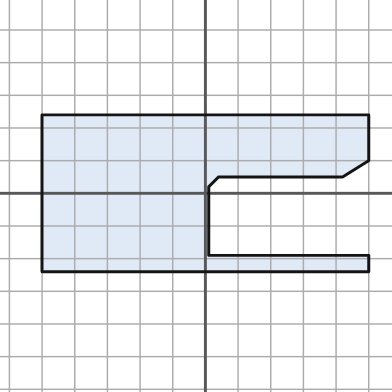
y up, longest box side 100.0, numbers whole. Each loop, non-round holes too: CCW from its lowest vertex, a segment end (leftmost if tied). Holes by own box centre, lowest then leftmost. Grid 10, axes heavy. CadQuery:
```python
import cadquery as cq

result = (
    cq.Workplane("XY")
    .moveTo(-50.0, -24.0)
    .lineTo(50.0, -24.0)
    .lineTo(50.0, -19.0)
    .lineTo(1.0, -19.0)
    .lineTo(1.0, 2.0)
    .lineTo(4.0, 5.0)
    .lineTo(42.0, 5.0)
    .lineTo(50.0, 10.0)
    .lineTo(50.0, 24.0)
    .lineTo(-50.0, 24.0)
    .close()
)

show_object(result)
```